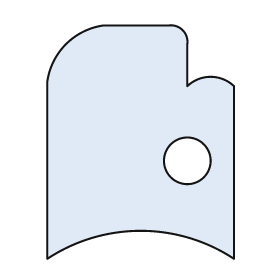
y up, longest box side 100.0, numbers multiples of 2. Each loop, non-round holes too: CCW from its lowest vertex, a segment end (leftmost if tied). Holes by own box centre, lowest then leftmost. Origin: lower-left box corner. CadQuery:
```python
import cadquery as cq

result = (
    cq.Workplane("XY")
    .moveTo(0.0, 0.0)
    .threePointArc((40.0, 12.0), (80.0, 0.0))
    .lineTo(80.0, 74.0)
    .threePointArc((70.0, 78.0), (60.0, 74.0))
    .lineTo(60.0, 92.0)
    .threePointArc((58.0, 98.0), (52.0, 100.0))
    .lineTo(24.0, 100.0)
    .threePointArc((8.0, 92.0), (0.0, 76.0))
    .close()
    .moveTo(60.0, 42.0)
    .circle(10.0)
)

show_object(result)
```